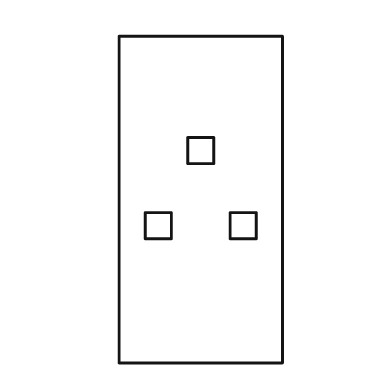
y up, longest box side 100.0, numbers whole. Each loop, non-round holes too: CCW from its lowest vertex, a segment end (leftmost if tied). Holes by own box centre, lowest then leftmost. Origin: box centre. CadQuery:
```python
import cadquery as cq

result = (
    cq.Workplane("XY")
    .moveTo(-25.0, -50.0)
    .lineTo(25.0, -50.0)
    .lineTo(25.0, 50.0)
    .lineTo(-25.0, 50.0)
    .close()
    .moveTo(-17.0, -12.0)
    .lineTo(-9.0, -12.0)
    .lineTo(-9.0, -4.0)
    .lineTo(-17.0, -4.0)
    .close()
    .moveTo(9.0, -12.0)
    .lineTo(17.0, -12.0)
    .lineTo(17.0, -4.0)
    .lineTo(9.0, -4.0)
    .close()
    .moveTo(-4.0, 11.0)
    .lineTo(4.0, 11.0)
    .lineTo(4.0, 19.0)
    .lineTo(-4.0, 19.0)
    .close()
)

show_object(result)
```